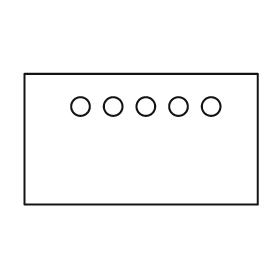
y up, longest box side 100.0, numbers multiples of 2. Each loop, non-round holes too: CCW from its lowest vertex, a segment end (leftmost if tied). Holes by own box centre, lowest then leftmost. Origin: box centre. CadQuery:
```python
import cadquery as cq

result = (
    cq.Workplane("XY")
    .moveTo(-50.0, -28.0)
    .lineTo(50.0, -28.0)
    .lineTo(50.0, 28.0)
    .lineTo(-50.0, 28.0)
    .close()
    .moveTo(-26.0, 14.0)
    .circle(4.0)
    .moveTo(-12.0, 14.0)
    .circle(4.0)
    .moveTo(2.0, 14.0)
    .circle(4.0)
    .moveTo(16.0, 14.0)
    .circle(4.0)
    .moveTo(30.0, 14.0)
    .circle(4.0)
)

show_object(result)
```